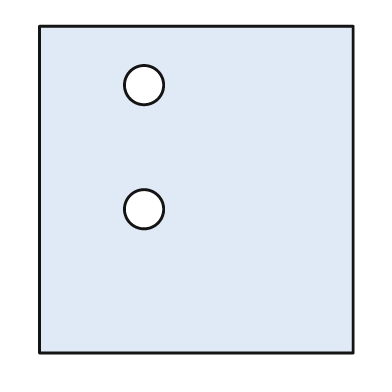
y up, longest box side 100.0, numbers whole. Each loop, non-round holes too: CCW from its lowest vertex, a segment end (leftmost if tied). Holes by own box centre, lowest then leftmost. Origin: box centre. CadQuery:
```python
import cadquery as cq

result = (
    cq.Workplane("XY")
    .moveTo(-48.0, -50.0)
    .lineTo(48.0, -50.0)
    .lineTo(48.0, 50.0)
    .lineTo(-48.0, 50.0)
    .close()
    .moveTo(-16.0, -6.0)
    .circle(6.0)
    .moveTo(-16.0, 32.0)
    .circle(6.0)
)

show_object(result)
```